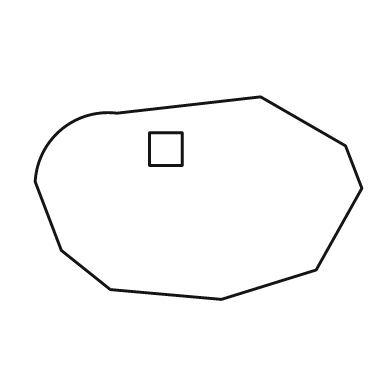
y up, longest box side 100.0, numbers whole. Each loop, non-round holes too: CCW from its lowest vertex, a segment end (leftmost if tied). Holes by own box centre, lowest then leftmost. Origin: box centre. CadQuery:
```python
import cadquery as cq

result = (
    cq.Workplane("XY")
    .moveTo(7.0, -31.0)
    .lineTo(36.0, -22.0)
    .lineTo(50.0, 3.0)
    .lineTo(45.0, 16.0)
    .lineTo(19.0, 31.0)
    .lineTo(-25.0, 26.0)
    .threePointArc((-42.0, 21.0), (-50.0, 5.0))
    .lineTo(-42.0, -16.0)
    .lineTo(-27.0, -28.0)
    .close()
    .moveTo(-15.0, 10.0)
    .lineTo(-5.0, 10.0)
    .lineTo(-5.0, 20.0)
    .lineTo(-15.0, 20.0)
    .close()
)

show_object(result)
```